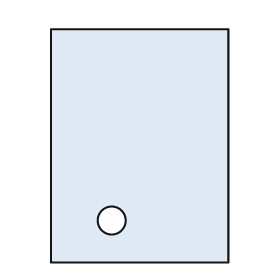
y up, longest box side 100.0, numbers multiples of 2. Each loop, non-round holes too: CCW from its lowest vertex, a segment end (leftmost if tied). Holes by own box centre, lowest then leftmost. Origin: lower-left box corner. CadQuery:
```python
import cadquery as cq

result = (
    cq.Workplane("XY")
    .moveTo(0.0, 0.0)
    .lineTo(76.0, 0.0)
    .lineTo(76.0, 100.0)
    .lineTo(0.0, 100.0)
    .close()
    .moveTo(26.0, 18.0)
    .circle(6.0)
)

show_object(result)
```